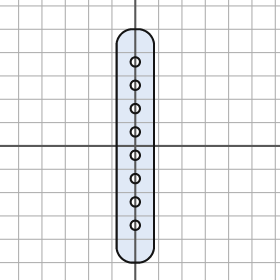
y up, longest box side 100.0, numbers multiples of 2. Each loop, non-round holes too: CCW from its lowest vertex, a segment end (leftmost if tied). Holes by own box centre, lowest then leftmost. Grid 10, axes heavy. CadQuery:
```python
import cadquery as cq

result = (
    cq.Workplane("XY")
    .moveTo(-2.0, -50.0)
    .lineTo(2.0, -50.0)
    .threePointArc((6.0, -48.0), (8.0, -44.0))
    .lineTo(8.0, 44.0)
    .threePointArc((6.0, 48.0), (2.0, 50.0))
    .lineTo(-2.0, 50.0)
    .threePointArc((-6.0, 48.0), (-8.0, 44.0))
    .lineTo(-8.0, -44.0)
    .threePointArc((-6.0, -48.0), (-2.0, -50.0))
    .close()
    .moveTo(0.0, -34.0)
    .circle(2.0)
    .moveTo(0.0, -24.0)
    .circle(2.0)
    .moveTo(0.0, -14.0)
    .circle(2.0)
    .moveTo(0.0, -4.0)
    .circle(2.0)
    .moveTo(0.0, 6.0)
    .circle(2.0)
    .moveTo(0.0, 16.0)
    .circle(2.0)
    .moveTo(0.0, 26.0)
    .circle(2.0)
    .moveTo(0.0, 36.0)
    .circle(2.0)
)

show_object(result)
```